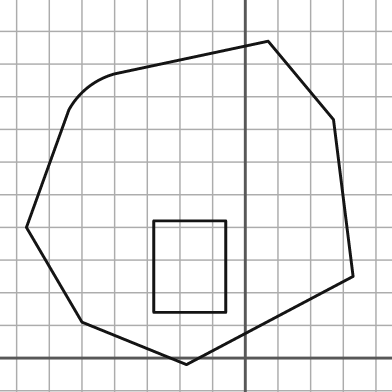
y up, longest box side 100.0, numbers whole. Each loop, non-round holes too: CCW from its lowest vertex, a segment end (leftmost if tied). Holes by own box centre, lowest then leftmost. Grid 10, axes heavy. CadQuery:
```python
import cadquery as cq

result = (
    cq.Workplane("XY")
    .moveTo(-18.0, -2.0)
    .lineTo(33.0, 25.0)
    .lineTo(27.0, 73.0)
    .lineTo(7.0, 97.0)
    .lineTo(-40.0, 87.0)
    .threePointArc((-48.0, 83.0), (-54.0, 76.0))
    .lineTo(-67.0, 40.0)
    .lineTo(-50.0, 11.0)
    .close()
    .moveTo(-28.0, 14.0)
    .lineTo(-6.0, 14.0)
    .lineTo(-6.0, 42.0)
    .lineTo(-28.0, 42.0)
    .close()
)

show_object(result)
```